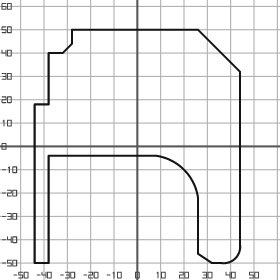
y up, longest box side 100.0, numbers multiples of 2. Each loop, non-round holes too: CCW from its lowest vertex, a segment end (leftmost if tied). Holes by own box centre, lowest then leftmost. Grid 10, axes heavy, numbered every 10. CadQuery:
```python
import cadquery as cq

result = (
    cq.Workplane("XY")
    .moveTo(-44.0, -50.0)
    .lineTo(-38.0, -50.0)
    .lineTo(-38.0, -4.0)
    .lineTo(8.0, -4.0)
    .threePointArc((20.0, -10.0), (26.0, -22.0))
    .lineTo(26.0, -46.0)
    .lineTo(32.0, -50.0)
    .lineTo(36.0, -50.0)
    .threePointArc((42.0, -48.0), (44.0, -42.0))
    .lineTo(44.0, 32.0)
    .lineTo(26.0, 50.0)
    .lineTo(-28.0, 50.0)
    .lineTo(-28.0, 44.0)
    .lineTo(-32.0, 40.0)
    .lineTo(-38.0, 40.0)
    .lineTo(-38.0, 18.0)
    .lineTo(-44.0, 18.0)
    .close()
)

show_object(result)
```